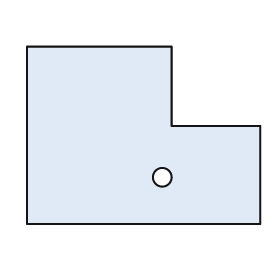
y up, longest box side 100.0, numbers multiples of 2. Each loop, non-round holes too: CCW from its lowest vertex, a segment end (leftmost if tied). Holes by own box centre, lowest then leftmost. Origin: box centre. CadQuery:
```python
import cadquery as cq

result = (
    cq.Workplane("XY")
    .moveTo(-50.0, -38.0)
    .lineTo(50.0, -38.0)
    .lineTo(50.0, 4.0)
    .lineTo(12.0, 4.0)
    .lineTo(12.0, 38.0)
    .lineTo(-50.0, 38.0)
    .close()
    .moveTo(8.0, -18.0)
    .circle(4.0)
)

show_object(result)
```